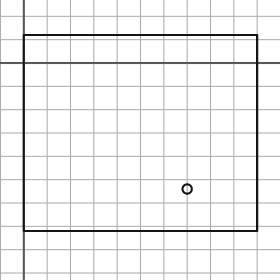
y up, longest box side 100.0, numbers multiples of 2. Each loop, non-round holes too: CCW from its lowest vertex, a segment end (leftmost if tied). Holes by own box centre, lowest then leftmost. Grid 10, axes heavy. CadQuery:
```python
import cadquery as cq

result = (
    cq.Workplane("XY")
    .moveTo(0.0, -72.0)
    .lineTo(100.0, -72.0)
    .lineTo(100.0, 12.0)
    .lineTo(0.0, 12.0)
    .close()
    .moveTo(70.0, -54.0)
    .circle(2.0)
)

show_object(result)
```